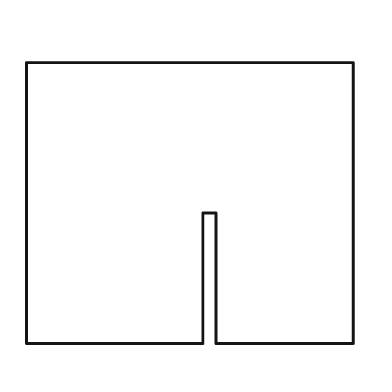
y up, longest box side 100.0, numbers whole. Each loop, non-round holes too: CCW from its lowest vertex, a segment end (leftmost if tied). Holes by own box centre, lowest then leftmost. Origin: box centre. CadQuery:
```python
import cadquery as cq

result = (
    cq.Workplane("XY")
    .moveTo(-50.0, -43.0)
    .lineTo(4.0, -43.0)
    .lineTo(4.0, -3.0)
    .lineTo(8.0, -3.0)
    .lineTo(8.0, -43.0)
    .lineTo(50.0, -43.0)
    .lineTo(50.0, 43.0)
    .lineTo(-50.0, 43.0)
    .close()
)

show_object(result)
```